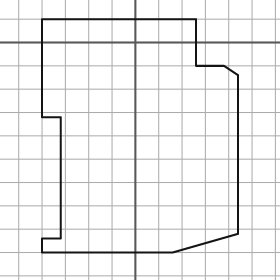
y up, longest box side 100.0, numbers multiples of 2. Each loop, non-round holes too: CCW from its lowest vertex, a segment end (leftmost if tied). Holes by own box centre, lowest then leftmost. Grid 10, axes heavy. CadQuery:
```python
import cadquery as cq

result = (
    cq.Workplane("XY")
    .moveTo(-40.0, -90.0)
    .lineTo(16.0, -90.0)
    .lineTo(44.0, -82.0)
    .lineTo(44.0, -14.0)
    .lineTo(38.0, -10.0)
    .lineTo(26.0, -10.0)
    .lineTo(26.0, 10.0)
    .lineTo(-40.0, 10.0)
    .lineTo(-40.0, -32.0)
    .lineTo(-32.0, -32.0)
    .lineTo(-32.0, -84.0)
    .lineTo(-40.0, -84.0)
    .close()
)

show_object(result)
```